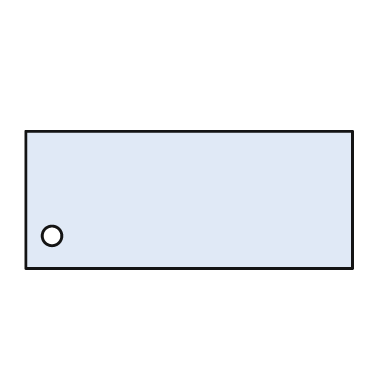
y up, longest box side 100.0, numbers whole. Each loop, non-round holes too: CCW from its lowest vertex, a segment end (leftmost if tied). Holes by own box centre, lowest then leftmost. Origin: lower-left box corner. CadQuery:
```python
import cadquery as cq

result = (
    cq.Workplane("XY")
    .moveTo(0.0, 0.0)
    .lineTo(100.0, 0.0)
    .lineTo(100.0, 42.0)
    .lineTo(0.0, 42.0)
    .close()
    .moveTo(8.0, 10.0)
    .circle(3.0)
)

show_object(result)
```